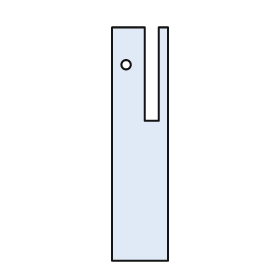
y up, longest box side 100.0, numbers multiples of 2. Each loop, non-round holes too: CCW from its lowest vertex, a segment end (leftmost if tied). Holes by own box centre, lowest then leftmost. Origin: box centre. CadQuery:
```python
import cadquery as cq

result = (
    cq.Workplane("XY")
    .moveTo(-12.0, -50.0)
    .lineTo(12.0, -50.0)
    .lineTo(12.0, 50.0)
    .lineTo(8.0, 50.0)
    .lineTo(8.0, 10.0)
    .lineTo(2.0, 10.0)
    .lineTo(2.0, 50.0)
    .lineTo(-12.0, 50.0)
    .close()
    .moveTo(-6.0, 34.0)
    .circle(2.0)
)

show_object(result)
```